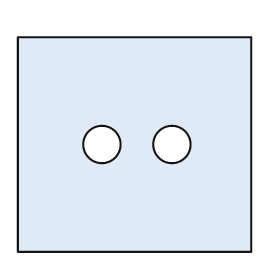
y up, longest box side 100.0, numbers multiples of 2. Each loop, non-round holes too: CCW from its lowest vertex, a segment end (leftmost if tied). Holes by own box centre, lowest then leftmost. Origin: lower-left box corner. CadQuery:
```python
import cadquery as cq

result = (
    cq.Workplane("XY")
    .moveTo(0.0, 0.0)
    .lineTo(100.0, 0.0)
    .lineTo(100.0, 92.0)
    .lineTo(0.0, 92.0)
    .close()
    .moveTo(36.0, 46.0)
    .circle(8.0)
    .moveTo(66.0, 46.0)
    .circle(8.0)
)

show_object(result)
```